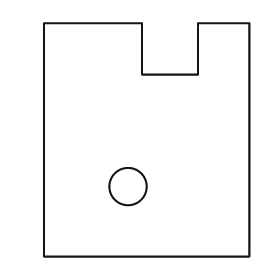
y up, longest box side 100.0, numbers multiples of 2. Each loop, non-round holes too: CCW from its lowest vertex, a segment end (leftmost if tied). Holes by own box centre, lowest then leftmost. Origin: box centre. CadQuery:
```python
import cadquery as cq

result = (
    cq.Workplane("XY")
    .moveTo(-44.0, -50.0)
    .lineTo(44.0, -50.0)
    .lineTo(44.0, 50.0)
    .lineTo(22.0, 50.0)
    .lineTo(22.0, 28.0)
    .lineTo(-2.0, 28.0)
    .lineTo(-2.0, 50.0)
    .lineTo(-44.0, 50.0)
    .close()
    .moveTo(-8.0, -20.0)
    .circle(8.0)
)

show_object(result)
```